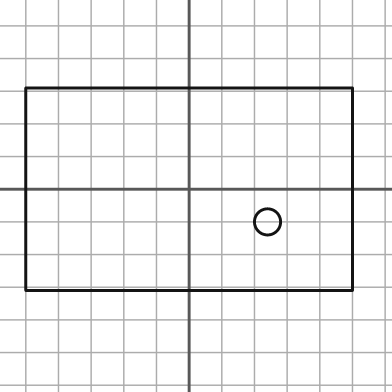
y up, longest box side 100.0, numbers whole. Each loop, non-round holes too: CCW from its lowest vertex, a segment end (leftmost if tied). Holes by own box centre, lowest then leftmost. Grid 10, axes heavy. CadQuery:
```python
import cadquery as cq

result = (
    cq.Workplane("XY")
    .moveTo(-50.0, -31.0)
    .lineTo(50.0, -31.0)
    .lineTo(50.0, 31.0)
    .lineTo(-50.0, 31.0)
    .close()
    .moveTo(24.0, -10.0)
    .circle(4.0)
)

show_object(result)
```